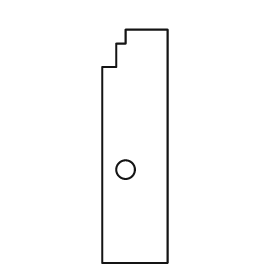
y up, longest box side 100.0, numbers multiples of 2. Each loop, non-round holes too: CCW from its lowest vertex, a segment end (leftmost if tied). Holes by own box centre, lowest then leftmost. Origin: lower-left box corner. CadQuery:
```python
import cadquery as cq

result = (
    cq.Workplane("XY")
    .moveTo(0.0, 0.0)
    .lineTo(28.0, 0.0)
    .lineTo(28.0, 100.0)
    .lineTo(10.0, 100.0)
    .lineTo(10.0, 94.0)
    .lineTo(6.0, 94.0)
    .lineTo(6.0, 84.0)
    .lineTo(0.0, 84.0)
    .close()
    .moveTo(10.0, 40.0)
    .circle(4.0)
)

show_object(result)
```